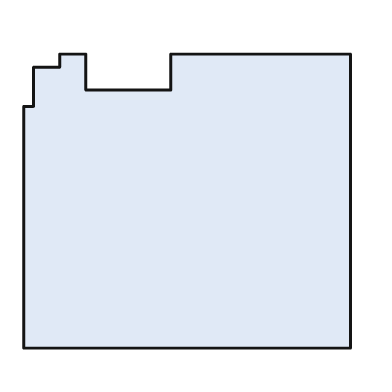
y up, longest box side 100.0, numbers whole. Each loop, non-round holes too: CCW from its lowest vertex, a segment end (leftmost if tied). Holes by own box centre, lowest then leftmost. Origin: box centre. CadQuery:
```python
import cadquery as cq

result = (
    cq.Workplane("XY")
    .moveTo(-50.0, -45.0)
    .lineTo(50.0, -45.0)
    .lineTo(50.0, 45.0)
    .lineTo(-5.0, 45.0)
    .lineTo(-5.0, 34.0)
    .lineTo(-31.0, 34.0)
    .lineTo(-31.0, 45.0)
    .lineTo(-39.0, 45.0)
    .lineTo(-39.0, 41.0)
    .lineTo(-47.0, 41.0)
    .lineTo(-47.0, 29.0)
    .lineTo(-50.0, 29.0)
    .close()
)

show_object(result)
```